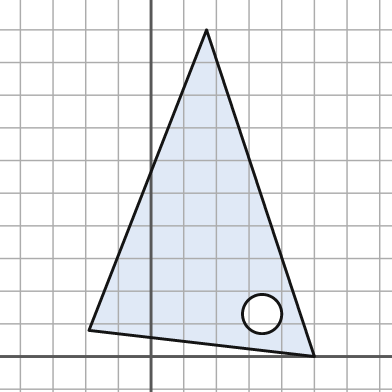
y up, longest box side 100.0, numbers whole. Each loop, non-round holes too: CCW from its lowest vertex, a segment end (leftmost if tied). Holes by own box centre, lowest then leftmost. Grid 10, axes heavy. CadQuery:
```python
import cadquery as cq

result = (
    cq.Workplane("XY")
    .moveTo(50.0, 0.0)
    .lineTo(17.0, 100.0)
    .lineTo(-19.0, 8.0)
    .close()
    .moveTo(34.0, 13.0)
    .circle(6.0)
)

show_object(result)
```